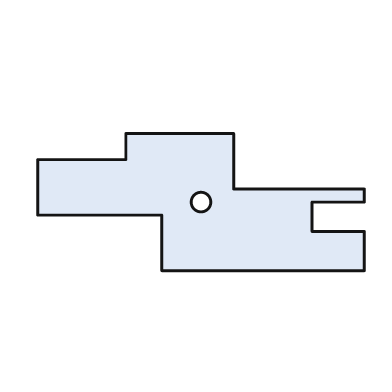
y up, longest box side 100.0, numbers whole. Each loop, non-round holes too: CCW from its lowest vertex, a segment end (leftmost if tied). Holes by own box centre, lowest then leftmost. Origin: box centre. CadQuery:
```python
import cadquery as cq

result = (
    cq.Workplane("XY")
    .moveTo(-12.0, -21.0)
    .lineTo(50.0, -21.0)
    .lineTo(50.0, -9.0)
    .lineTo(34.0, -9.0)
    .lineTo(34.0, 0.0)
    .lineTo(50.0, 0.0)
    .lineTo(50.0, 4.0)
    .lineTo(10.0, 4.0)
    .lineTo(10.0, 21.0)
    .lineTo(-23.0, 21.0)
    .lineTo(-23.0, 13.0)
    .lineTo(-50.0, 13.0)
    .lineTo(-50.0, -4.0)
    .lineTo(-12.0, -4.0)
    .close()
    .moveTo(0.0, 0.0)
    .circle(3.0)
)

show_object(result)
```